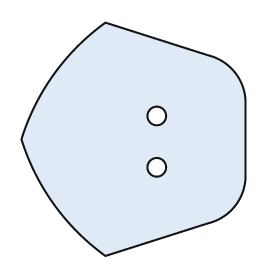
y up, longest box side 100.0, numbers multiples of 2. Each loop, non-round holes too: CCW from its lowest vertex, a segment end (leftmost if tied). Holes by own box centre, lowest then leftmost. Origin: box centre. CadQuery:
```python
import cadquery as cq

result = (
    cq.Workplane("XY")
    .moveTo(-12.0, -50.0)
    .lineTo(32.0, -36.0)
    .threePointArc((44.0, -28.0), (48.0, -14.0))
    .lineTo(48.0, 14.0)
    .threePointArc((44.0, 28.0), (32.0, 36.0))
    .lineTo(-12.0, 50.0)
    .threePointArc((-34.0, 28.0), (-48.0, 0.0))
    .threePointArc((-34.0, -28.0), (-12.0, -50.0))
    .close()
    .moveTo(10.0, -12.0)
    .circle(4.0)
    .moveTo(10.0, 10.0)
    .circle(4.0)
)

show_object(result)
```